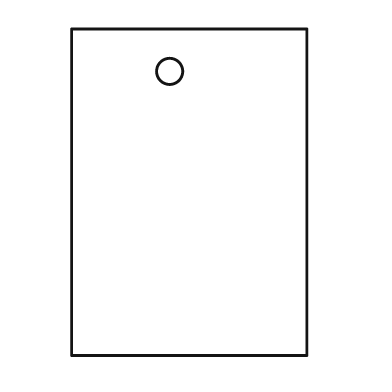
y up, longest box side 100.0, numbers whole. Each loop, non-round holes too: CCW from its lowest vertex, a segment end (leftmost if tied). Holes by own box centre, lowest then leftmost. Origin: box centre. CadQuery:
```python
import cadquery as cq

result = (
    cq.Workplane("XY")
    .moveTo(-36.0, -50.0)
    .lineTo(36.0, -50.0)
    .lineTo(36.0, 50.0)
    .lineTo(-36.0, 50.0)
    .close()
    .moveTo(-6.0, 37.0)
    .circle(4.0)
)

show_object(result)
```